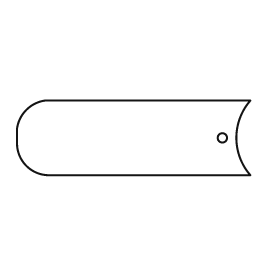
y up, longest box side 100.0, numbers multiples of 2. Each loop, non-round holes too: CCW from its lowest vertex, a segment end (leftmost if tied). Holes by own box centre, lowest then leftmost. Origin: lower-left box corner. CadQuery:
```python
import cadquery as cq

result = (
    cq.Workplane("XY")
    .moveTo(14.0, 0.0)
    .lineTo(100.0, 0.0)
    .threePointArc((94.0, 16.0), (100.0, 32.0))
    .lineTo(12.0, 32.0)
    .threePointArc((4.0, 28.0), (0.0, 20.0))
    .lineTo(0.0, 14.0)
    .threePointArc((4.0, 4.0), (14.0, 0.0))
    .close()
    .moveTo(88.0, 16.0)
    .circle(2.0)
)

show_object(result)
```